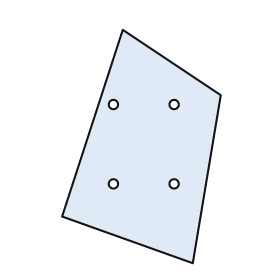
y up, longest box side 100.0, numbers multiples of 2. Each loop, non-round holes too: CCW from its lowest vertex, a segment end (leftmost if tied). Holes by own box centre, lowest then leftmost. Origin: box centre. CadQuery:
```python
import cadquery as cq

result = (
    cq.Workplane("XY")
    .moveTo(22.0, -50.0)
    .lineTo(34.0, 22.0)
    .lineTo(-8.0, 50.0)
    .lineTo(-34.0, -30.0)
    .close()
    .moveTo(-12.0, -16.0)
    .circle(2.0)
    .moveTo(14.0, -16.0)
    .circle(2.0)
    .moveTo(-12.0, 18.0)
    .circle(2.0)
    .moveTo(14.0, 18.0)
    .circle(2.0)
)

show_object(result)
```